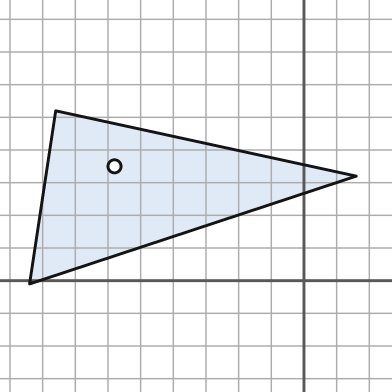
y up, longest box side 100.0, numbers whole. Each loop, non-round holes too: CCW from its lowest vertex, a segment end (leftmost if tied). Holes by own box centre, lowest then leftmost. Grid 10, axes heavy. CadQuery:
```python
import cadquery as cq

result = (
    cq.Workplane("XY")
    .moveTo(-84.0, -1.0)
    .lineTo(16.0, 32.0)
    .lineTo(-76.0, 52.0)
    .close()
    .moveTo(-58.0, 35.0)
    .circle(2.0)
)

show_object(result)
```